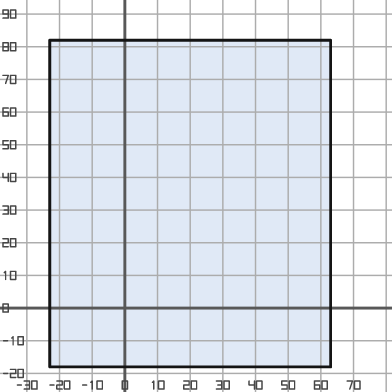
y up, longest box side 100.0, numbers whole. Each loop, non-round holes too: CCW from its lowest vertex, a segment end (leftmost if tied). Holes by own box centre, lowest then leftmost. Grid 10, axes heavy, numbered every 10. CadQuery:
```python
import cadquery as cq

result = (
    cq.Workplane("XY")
    .moveTo(-23.0, -18.0)
    .lineTo(63.0, -18.0)
    .lineTo(63.0, 82.0)
    .lineTo(-23.0, 82.0)
    .close()
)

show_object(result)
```